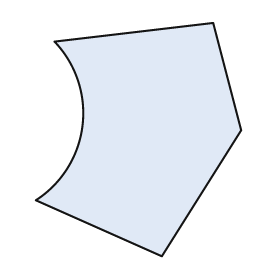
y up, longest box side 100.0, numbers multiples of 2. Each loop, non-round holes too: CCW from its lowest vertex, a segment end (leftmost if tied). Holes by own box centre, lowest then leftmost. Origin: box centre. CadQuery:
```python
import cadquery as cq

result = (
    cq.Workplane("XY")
    .moveTo(10.0, -50.0)
    .lineTo(44.0, 4.0)
    .lineTo(32.0, 50.0)
    .lineTo(-36.0, 42.0)
    .threePointArc((-24.0, 6.0), (-44.0, -26.0))
    .close()
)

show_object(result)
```